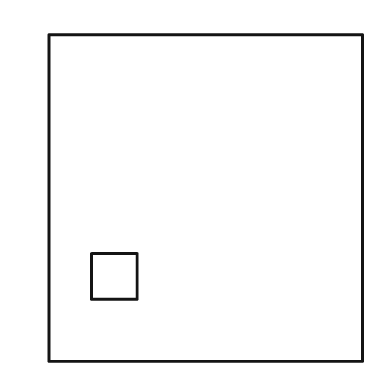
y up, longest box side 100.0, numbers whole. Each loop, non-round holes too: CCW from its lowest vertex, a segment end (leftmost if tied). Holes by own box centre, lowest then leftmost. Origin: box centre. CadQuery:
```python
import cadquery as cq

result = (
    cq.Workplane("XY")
    .moveTo(-48.0, -50.0)
    .lineTo(48.0, -50.0)
    .lineTo(48.0, 50.0)
    .lineTo(-48.0, 50.0)
    .close()
    .moveTo(-35.0, -31.0)
    .lineTo(-21.0, -31.0)
    .lineTo(-21.0, -17.0)
    .lineTo(-35.0, -17.0)
    .close()
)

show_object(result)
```